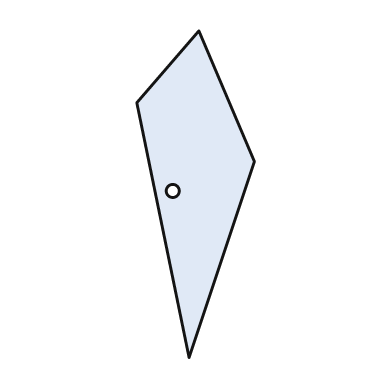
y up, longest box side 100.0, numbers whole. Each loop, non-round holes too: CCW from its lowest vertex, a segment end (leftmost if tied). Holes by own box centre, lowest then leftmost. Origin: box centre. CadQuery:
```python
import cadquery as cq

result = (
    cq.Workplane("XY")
    .moveTo(-2.0, -50.0)
    .lineTo(18.0, 10.0)
    .lineTo(1.0, 50.0)
    .lineTo(-18.0, 28.0)
    .close()
    .moveTo(-7.0, 1.0)
    .circle(2.0)
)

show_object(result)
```